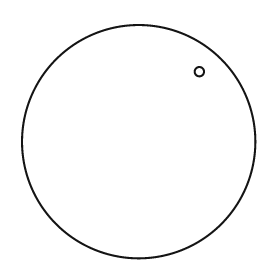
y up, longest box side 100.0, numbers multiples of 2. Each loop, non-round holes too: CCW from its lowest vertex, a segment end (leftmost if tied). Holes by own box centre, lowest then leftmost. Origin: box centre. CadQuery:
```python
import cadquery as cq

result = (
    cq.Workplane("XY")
    .moveTo(0.0, 0.0)
    .circle(50.0)
    .moveTo(26.0, 30.0)
    .circle(2.0)
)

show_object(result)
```